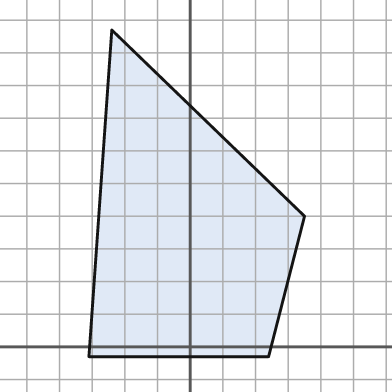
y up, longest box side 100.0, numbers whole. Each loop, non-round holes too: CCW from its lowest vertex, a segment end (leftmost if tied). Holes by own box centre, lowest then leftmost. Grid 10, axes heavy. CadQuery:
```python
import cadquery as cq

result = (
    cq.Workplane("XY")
    .moveTo(-31.0, -3.0)
    .lineTo(24.0, -3.0)
    .lineTo(35.0, 40.0)
    .lineTo(-24.0, 97.0)
    .close()
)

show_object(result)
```